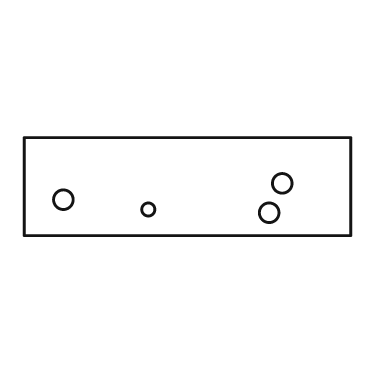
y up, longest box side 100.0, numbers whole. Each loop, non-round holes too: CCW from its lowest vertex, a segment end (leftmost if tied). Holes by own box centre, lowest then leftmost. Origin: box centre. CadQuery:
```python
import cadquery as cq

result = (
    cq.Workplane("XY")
    .moveTo(-50.0, -15.0)
    .lineTo(50.0, -15.0)
    .lineTo(50.0, 15.0)
    .lineTo(-50.0, 15.0)
    .close()
    .moveTo(25.0, -8.0)
    .circle(3.0)
    .moveTo(-12.0, -7.0)
    .circle(2.0)
    .moveTo(-38.0, -4.0)
    .circle(3.0)
    .moveTo(29.0, 1.0)
    .circle(3.0)
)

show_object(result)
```